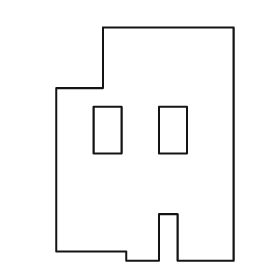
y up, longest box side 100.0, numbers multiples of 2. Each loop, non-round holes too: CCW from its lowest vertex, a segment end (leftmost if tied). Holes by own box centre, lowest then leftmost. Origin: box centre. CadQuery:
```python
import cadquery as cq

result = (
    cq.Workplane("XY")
    .moveTo(-8.0, -50.0)
    .lineTo(6.0, -50.0)
    .lineTo(6.0, -30.0)
    .lineTo(14.0, -30.0)
    .lineTo(14.0, -50.0)
    .lineTo(38.0, -50.0)
    .lineTo(38.0, 50.0)
    .lineTo(-18.0, 50.0)
    .lineTo(-18.0, 24.0)
    .lineTo(-38.0, 24.0)
    .lineTo(-38.0, -46.0)
    .lineTo(-8.0, -46.0)
    .close()
    .moveTo(-22.0, -4.0)
    .lineTo(-10.0, -4.0)
    .lineTo(-10.0, 16.0)
    .lineTo(-22.0, 16.0)
    .close()
    .moveTo(6.0, -4.0)
    .lineTo(18.0, -4.0)
    .lineTo(18.0, 16.0)
    .lineTo(6.0, 16.0)
    .close()
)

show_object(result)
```